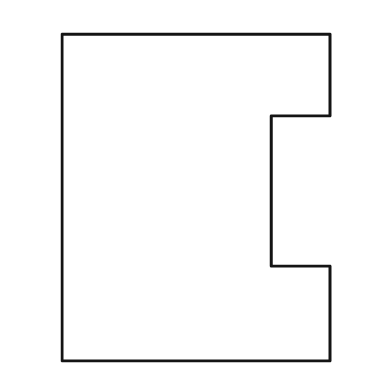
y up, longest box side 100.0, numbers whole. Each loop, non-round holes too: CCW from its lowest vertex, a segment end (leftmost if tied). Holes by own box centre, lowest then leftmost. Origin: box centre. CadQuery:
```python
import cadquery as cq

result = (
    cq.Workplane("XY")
    .moveTo(-41.0, -50.0)
    .lineTo(41.0, -50.0)
    .lineTo(41.0, -21.0)
    .lineTo(23.0, -21.0)
    .lineTo(23.0, 25.0)
    .lineTo(41.0, 25.0)
    .lineTo(41.0, 50.0)
    .lineTo(-41.0, 50.0)
    .close()
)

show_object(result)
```